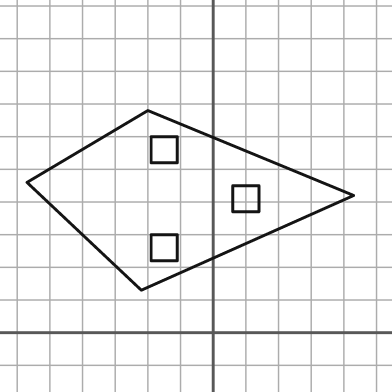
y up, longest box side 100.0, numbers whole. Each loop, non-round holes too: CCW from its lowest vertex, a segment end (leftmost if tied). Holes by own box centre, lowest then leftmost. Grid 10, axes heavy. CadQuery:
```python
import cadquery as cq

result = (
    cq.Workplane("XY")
    .moveTo(-22.0, 13.0)
    .lineTo(43.0, 42.0)
    .lineTo(-20.0, 68.0)
    .lineTo(-57.0, 46.0)
    .close()
    .moveTo(-19.0, 22.0)
    .lineTo(-11.0, 22.0)
    .lineTo(-11.0, 30.0)
    .lineTo(-19.0, 30.0)
    .close()
    .moveTo(6.0, 37.0)
    .lineTo(14.0, 37.0)
    .lineTo(14.0, 45.0)
    .lineTo(6.0, 45.0)
    .close()
    .moveTo(-19.0, 52.0)
    .lineTo(-11.0, 52.0)
    .lineTo(-11.0, 60.0)
    .lineTo(-19.0, 60.0)
    .close()
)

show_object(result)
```